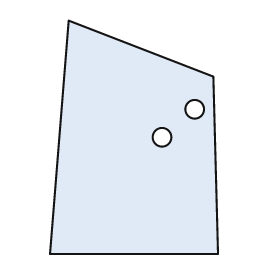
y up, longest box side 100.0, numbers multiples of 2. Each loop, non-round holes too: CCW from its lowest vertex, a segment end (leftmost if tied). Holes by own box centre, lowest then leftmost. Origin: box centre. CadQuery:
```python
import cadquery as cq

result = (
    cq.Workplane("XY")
    .moveTo(-36.0, -50.0)
    .lineTo(36.0, -50.0)
    .lineTo(34.0, 26.0)
    .lineTo(-28.0, 50.0)
    .close()
    .moveTo(12.0, 0.0)
    .circle(4.0)
    .moveTo(26.0, 12.0)
    .circle(4.0)
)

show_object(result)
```